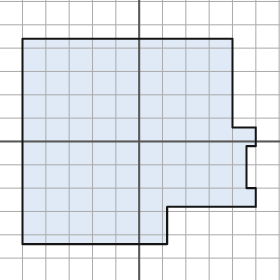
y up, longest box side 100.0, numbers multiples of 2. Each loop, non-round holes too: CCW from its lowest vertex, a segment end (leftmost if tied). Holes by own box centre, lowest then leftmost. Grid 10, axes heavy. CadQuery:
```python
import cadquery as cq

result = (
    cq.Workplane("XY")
    .moveTo(-50.0, -44.0)
    .lineTo(12.0, -44.0)
    .lineTo(12.0, -28.0)
    .lineTo(50.0, -28.0)
    .lineTo(50.0, -20.0)
    .lineTo(46.0, -20.0)
    .lineTo(46.0, -2.0)
    .lineTo(50.0, -2.0)
    .lineTo(50.0, 6.0)
    .lineTo(40.0, 6.0)
    .lineTo(40.0, 44.0)
    .lineTo(-50.0, 44.0)
    .close()
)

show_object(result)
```